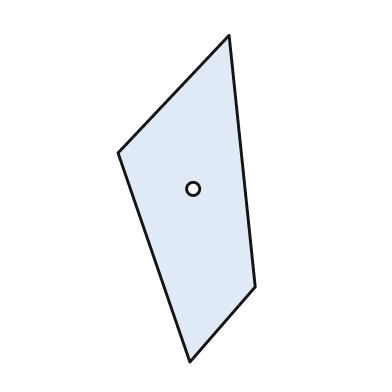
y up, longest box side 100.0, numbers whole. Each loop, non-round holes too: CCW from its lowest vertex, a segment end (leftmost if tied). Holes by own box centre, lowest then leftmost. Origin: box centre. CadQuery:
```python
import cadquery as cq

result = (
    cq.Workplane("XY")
    .moveTo(1.0, -50.0)
    .lineTo(21.0, -27.0)
    .lineTo(13.0, 50.0)
    .lineTo(-21.0, 14.0)
    .close()
    .moveTo(2.0, 3.0)
    .circle(2.0)
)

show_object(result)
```